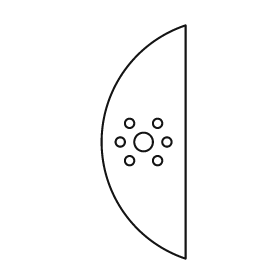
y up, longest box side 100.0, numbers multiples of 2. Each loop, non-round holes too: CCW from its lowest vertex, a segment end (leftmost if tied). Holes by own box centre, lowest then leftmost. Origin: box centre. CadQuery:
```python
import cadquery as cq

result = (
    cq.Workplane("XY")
    .moveTo(18.0, -50.0)
    .lineTo(18.0, 50.0)
    .threePointArc((-18.0, 0.0), (18.0, -50.0))
    .close()
    .moveTo(-6.0, -8.0)
    .circle(2.0)
    .moveTo(6.0, -8.0)
    .circle(2.0)
    .moveTo(-10.0, 0.0)
    .circle(2.0)
    .moveTo(0.0, 0.0)
    .circle(4.0)
    .moveTo(10.0, 0.0)
    .circle(2.0)
    .moveTo(-6.0, 8.0)
    .circle(2.0)
    .moveTo(6.0, 8.0)
    .circle(2.0)
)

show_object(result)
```